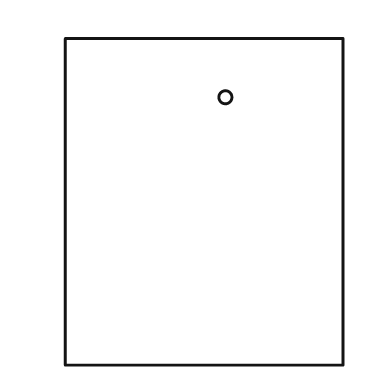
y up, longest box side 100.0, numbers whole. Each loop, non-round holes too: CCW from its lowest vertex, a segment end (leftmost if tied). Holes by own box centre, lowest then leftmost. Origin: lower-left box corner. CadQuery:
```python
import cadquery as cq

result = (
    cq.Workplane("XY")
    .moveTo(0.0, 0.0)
    .lineTo(85.0, 0.0)
    .lineTo(85.0, 100.0)
    .lineTo(0.0, 100.0)
    .close()
    .moveTo(49.0, 82.0)
    .circle(2.0)
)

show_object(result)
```